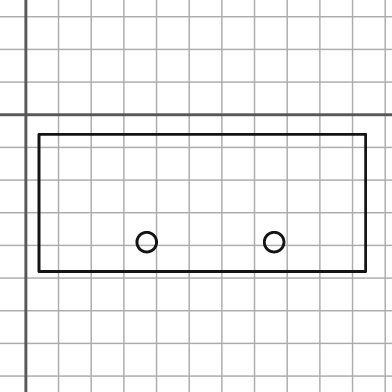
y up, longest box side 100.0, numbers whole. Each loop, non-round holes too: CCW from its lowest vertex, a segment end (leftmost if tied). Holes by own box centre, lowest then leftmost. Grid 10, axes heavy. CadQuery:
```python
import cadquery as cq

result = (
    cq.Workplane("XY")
    .moveTo(4.0, -48.0)
    .lineTo(104.0, -48.0)
    .lineTo(104.0, -6.0)
    .lineTo(4.0, -6.0)
    .close()
    .moveTo(37.0, -39.0)
    .circle(3.0)
    .moveTo(76.0, -39.0)
    .circle(3.0)
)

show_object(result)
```